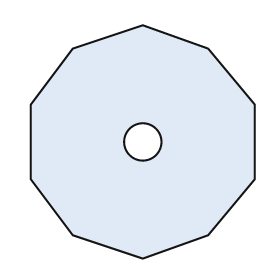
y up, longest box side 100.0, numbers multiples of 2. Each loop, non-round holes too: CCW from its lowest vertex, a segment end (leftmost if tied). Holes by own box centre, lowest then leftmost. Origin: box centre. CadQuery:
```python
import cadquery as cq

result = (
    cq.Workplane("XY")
    .moveTo(0.0, -50.0)
    .lineTo(28.0, -40.0)
    .lineTo(48.0, -16.0)
    .lineTo(48.0, 16.0)
    .lineTo(28.0, 40.0)
    .lineTo(0.0, 50.0)
    .lineTo(-30.0, 40.0)
    .lineTo(-48.0, 16.0)
    .lineTo(-48.0, -16.0)
    .lineTo(-30.0, -40.0)
    .close()
    .moveTo(0.0, 0.0)
    .circle(8.0)
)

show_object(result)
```